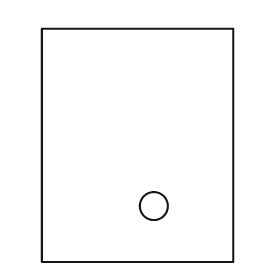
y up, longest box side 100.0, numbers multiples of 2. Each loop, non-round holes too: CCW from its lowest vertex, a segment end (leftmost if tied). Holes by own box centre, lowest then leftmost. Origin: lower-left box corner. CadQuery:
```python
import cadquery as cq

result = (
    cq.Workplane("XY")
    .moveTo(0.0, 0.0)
    .lineTo(82.0, 0.0)
    .lineTo(82.0, 100.0)
    .lineTo(0.0, 100.0)
    .close()
    .moveTo(48.0, 24.0)
    .circle(6.0)
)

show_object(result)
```